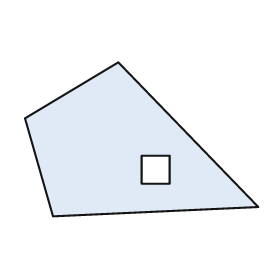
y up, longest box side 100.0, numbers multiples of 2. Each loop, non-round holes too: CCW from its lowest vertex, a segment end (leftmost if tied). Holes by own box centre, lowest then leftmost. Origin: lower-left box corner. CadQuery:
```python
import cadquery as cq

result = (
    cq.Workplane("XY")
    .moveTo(12.0, 0.0)
    .lineTo(100.0, 4.0)
    .lineTo(40.0, 66.0)
    .lineTo(0.0, 42.0)
    .close()
    .moveTo(50.0, 14.0)
    .lineTo(62.0, 14.0)
    .lineTo(62.0, 26.0)
    .lineTo(50.0, 26.0)
    .close()
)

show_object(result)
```